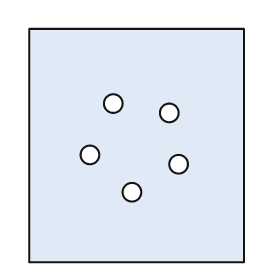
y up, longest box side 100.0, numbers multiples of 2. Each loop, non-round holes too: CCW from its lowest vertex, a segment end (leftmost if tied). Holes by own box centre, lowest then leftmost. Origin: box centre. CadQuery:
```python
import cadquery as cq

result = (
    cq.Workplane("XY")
    .moveTo(-46.0, -50.0)
    .lineTo(46.0, -50.0)
    .lineTo(46.0, 50.0)
    .lineTo(-46.0, 50.0)
    .close()
    .moveTo(-2.0, -20.0)
    .circle(4.0)
    .moveTo(18.0, -8.0)
    .circle(4.0)
    .moveTo(-20.0, -4.0)
    .circle(4.0)
    .moveTo(14.0, 14.0)
    .circle(4.0)
    .moveTo(-10.0, 18.0)
    .circle(4.0)
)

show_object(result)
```